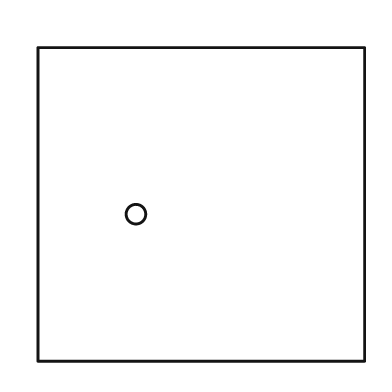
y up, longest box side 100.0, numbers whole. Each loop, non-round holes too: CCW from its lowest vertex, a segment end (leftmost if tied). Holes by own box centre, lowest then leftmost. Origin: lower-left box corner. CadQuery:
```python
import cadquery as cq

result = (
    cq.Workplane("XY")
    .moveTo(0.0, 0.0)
    .lineTo(100.0, 0.0)
    .lineTo(100.0, 96.0)
    .lineTo(0.0, 96.0)
    .close()
    .moveTo(30.0, 45.0)
    .circle(3.0)
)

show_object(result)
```